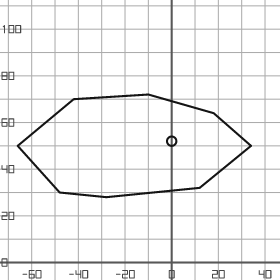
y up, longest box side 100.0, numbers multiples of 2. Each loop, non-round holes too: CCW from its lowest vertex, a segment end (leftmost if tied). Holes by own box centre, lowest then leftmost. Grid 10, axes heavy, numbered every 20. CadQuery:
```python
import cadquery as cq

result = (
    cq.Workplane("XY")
    .moveTo(-28.0, 28.0)
    .lineTo(12.0, 32.0)
    .lineTo(34.0, 50.0)
    .lineTo(18.0, 64.0)
    .lineTo(-10.0, 72.0)
    .lineTo(-42.0, 70.0)
    .lineTo(-66.0, 50.0)
    .lineTo(-48.0, 30.0)
    .close()
    .moveTo(0.0, 52.0)
    .circle(2.0)
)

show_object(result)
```